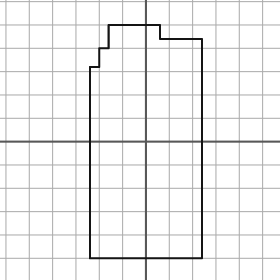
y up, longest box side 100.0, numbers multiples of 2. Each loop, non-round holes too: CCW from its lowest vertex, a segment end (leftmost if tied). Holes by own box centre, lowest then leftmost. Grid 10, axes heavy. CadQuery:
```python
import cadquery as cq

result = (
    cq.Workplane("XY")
    .moveTo(-24.0, -50.0)
    .lineTo(24.0, -50.0)
    .lineTo(24.0, 44.0)
    .lineTo(6.0, 44.0)
    .lineTo(6.0, 50.0)
    .lineTo(-16.0, 50.0)
    .lineTo(-16.0, 40.0)
    .lineTo(-20.0, 40.0)
    .lineTo(-20.0, 32.0)
    .lineTo(-24.0, 32.0)
    .close()
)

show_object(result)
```